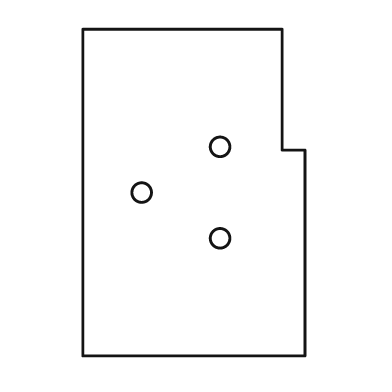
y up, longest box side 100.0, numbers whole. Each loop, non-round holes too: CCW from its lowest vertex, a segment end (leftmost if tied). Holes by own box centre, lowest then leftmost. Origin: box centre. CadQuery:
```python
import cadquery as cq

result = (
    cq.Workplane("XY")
    .moveTo(-34.0, -50.0)
    .lineTo(34.0, -50.0)
    .lineTo(34.0, 13.0)
    .lineTo(27.0, 13.0)
    .lineTo(27.0, 50.0)
    .lineTo(-34.0, 50.0)
    .close()
    .moveTo(8.0, -14.0)
    .circle(3.0)
    .moveTo(-16.0, 0.0)
    .circle(3.0)
    .moveTo(8.0, 14.0)
    .circle(3.0)
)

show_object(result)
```